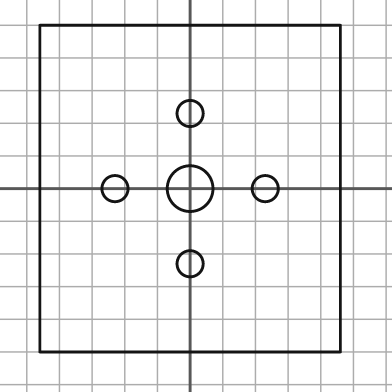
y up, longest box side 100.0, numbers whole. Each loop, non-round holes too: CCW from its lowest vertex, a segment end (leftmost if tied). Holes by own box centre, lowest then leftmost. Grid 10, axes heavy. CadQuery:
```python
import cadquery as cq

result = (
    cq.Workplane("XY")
    .moveTo(-46.0, -50.0)
    .lineTo(46.0, -50.0)
    .lineTo(46.0, 50.0)
    .lineTo(-46.0, 50.0)
    .close()
    .moveTo(0.0, -23.0)
    .circle(4.0)
    .moveTo(-23.0, 0.0)
    .circle(4.0)
    .moveTo(0.0, 0.0)
    .circle(7.0)
    .moveTo(23.0, 0.0)
    .circle(4.0)
    .moveTo(0.0, 23.0)
    .circle(4.0)
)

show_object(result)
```